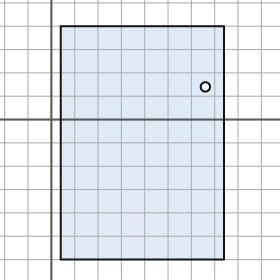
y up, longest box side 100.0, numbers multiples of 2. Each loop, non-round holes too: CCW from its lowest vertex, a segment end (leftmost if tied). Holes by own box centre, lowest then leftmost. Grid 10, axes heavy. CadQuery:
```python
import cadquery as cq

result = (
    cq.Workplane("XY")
    .moveTo(4.0, -60.0)
    .lineTo(74.0, -60.0)
    .lineTo(74.0, 40.0)
    .lineTo(4.0, 40.0)
    .close()
    .moveTo(66.0, 14.0)
    .circle(2.0)
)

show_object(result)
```